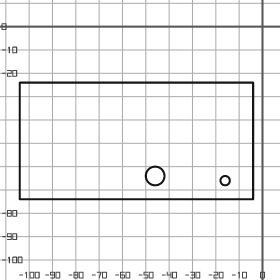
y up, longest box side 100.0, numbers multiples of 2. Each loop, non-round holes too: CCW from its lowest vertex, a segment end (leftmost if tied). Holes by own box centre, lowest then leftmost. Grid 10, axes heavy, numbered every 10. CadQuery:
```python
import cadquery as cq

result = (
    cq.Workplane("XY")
    .moveTo(-104.0, -74.0)
    .lineTo(-4.0, -74.0)
    .lineTo(-4.0, -24.0)
    .lineTo(-104.0, -24.0)
    .close()
    .moveTo(-16.0, -66.0)
    .circle(2.0)
    .moveTo(-46.0, -64.0)
    .circle(4.0)
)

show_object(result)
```